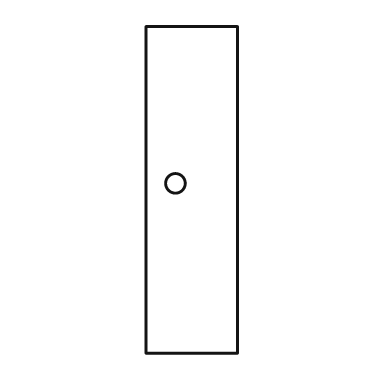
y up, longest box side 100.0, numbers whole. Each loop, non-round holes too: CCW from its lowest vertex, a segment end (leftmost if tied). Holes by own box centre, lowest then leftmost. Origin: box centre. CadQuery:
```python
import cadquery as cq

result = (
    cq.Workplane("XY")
    .moveTo(-14.0, -50.0)
    .lineTo(14.0, -50.0)
    .lineTo(14.0, 50.0)
    .lineTo(-14.0, 50.0)
    .close()
    .moveTo(-5.0, 2.0)
    .circle(3.0)
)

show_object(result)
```